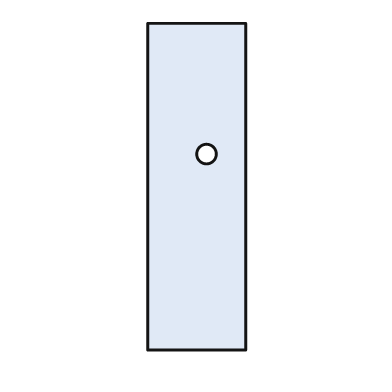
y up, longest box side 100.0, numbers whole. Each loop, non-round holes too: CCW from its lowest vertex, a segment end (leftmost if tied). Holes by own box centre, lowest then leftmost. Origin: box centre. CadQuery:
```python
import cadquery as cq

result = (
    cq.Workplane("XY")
    .moveTo(-15.0, -50.0)
    .lineTo(15.0, -50.0)
    .lineTo(15.0, 50.0)
    .lineTo(-15.0, 50.0)
    .close()
    .moveTo(3.0, 10.0)
    .circle(3.0)
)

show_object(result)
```